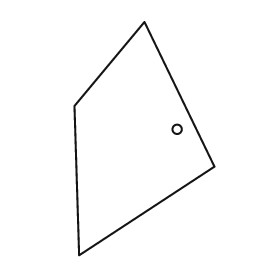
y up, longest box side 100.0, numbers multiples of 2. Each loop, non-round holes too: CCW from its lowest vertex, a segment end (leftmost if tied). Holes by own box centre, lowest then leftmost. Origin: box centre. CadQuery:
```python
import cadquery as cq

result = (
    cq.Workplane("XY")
    .moveTo(-28.0, -50.0)
    .lineTo(30.0, -12.0)
    .lineTo(0.0, 50.0)
    .lineTo(-30.0, 14.0)
    .close()
    .moveTo(14.0, 4.0)
    .circle(2.0)
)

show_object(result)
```